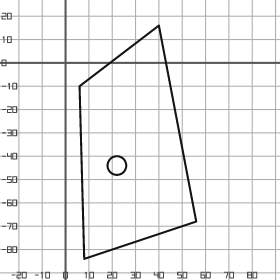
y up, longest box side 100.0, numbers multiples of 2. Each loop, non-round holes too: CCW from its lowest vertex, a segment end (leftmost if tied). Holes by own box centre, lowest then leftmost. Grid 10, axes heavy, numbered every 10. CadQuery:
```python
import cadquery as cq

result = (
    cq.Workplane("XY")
    .moveTo(8.0, -84.0)
    .lineTo(56.0, -68.0)
    .lineTo(40.0, 16.0)
    .lineTo(6.0, -10.0)
    .close()
    .moveTo(22.0, -44.0)
    .circle(4.0)
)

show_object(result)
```